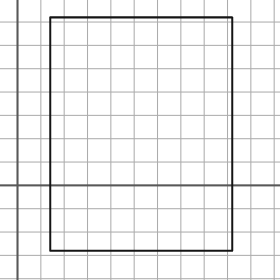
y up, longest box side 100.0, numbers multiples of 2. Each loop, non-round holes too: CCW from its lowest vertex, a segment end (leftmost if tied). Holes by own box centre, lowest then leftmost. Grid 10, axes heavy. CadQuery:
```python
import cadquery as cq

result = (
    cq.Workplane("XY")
    .moveTo(14.0, -28.0)
    .lineTo(92.0, -28.0)
    .lineTo(92.0, 72.0)
    .lineTo(14.0, 72.0)
    .close()
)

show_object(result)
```